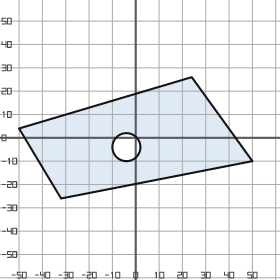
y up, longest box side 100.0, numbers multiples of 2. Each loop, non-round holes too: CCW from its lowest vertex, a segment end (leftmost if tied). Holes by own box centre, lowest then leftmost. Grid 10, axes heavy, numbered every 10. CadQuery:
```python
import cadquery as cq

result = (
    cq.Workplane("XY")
    .moveTo(-32.0, -26.0)
    .lineTo(50.0, -10.0)
    .lineTo(24.0, 26.0)
    .lineTo(-50.0, 4.0)
    .close()
    .moveTo(-4.0, -4.0)
    .circle(6.0)
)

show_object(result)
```